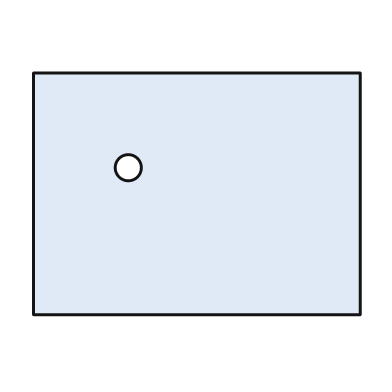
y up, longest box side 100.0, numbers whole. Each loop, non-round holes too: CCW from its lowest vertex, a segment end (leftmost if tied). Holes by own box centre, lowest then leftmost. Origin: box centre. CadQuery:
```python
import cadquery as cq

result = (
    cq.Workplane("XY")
    .moveTo(-50.0, -37.0)
    .lineTo(50.0, -37.0)
    .lineTo(50.0, 37.0)
    .lineTo(-50.0, 37.0)
    .close()
    .moveTo(-21.0, 8.0)
    .circle(4.0)
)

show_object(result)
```